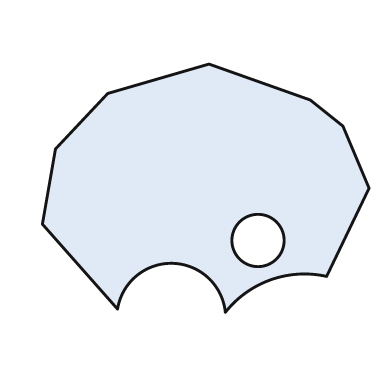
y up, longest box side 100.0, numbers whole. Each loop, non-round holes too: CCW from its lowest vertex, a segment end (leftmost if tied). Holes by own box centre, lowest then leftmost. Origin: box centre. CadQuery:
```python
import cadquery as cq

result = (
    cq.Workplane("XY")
    .moveTo(6.0, -38.0)
    .threePointArc((20.0, -28.0), (37.0, -27.0))
    .lineTo(50.0, 0.0)
    .lineTo(42.0, 19.0)
    .lineTo(32.0, 27.0)
    .lineTo(1.0, 38.0)
    .lineTo(-30.0, 29.0)
    .lineTo(-46.0, 12.0)
    .lineTo(-50.0, -11.0)
    .lineTo(-27.0, -37.0)
    .threePointArc((-10.0, -23.0), (6.0, -38.0))
    .close()
    .moveTo(16.0, -16.0)
    .circle(8.0)
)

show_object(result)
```